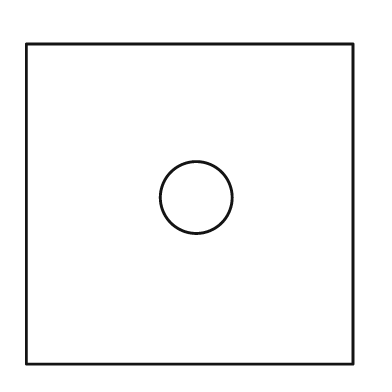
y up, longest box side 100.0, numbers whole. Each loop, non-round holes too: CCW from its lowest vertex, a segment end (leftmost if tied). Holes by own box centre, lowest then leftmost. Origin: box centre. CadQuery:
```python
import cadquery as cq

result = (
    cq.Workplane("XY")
    .moveTo(-50.0, -49.0)
    .lineTo(50.0, -49.0)
    .lineTo(50.0, 49.0)
    .lineTo(-50.0, 49.0)
    .close()
    .moveTo(2.0, 2.0)
    .circle(11.0)
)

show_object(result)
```